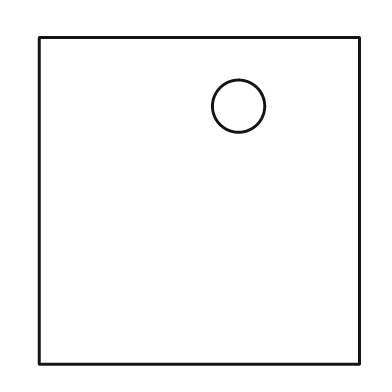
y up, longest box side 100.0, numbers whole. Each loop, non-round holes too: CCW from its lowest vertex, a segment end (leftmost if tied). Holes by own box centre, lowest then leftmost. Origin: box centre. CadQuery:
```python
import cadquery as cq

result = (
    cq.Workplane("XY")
    .moveTo(-49.0, -50.0)
    .lineTo(49.0, -50.0)
    .lineTo(49.0, 50.0)
    .lineTo(-49.0, 50.0)
    .close()
    .moveTo(12.0, 29.0)
    .circle(8.0)
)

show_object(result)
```